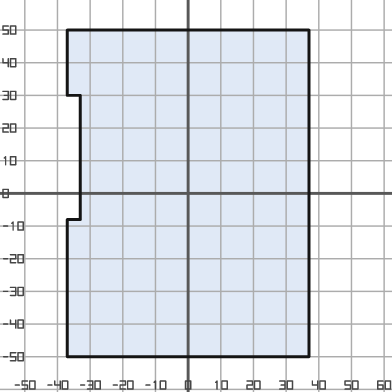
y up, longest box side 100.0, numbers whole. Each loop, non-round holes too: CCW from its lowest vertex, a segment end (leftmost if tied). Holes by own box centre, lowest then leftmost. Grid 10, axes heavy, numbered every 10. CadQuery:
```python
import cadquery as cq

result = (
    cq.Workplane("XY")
    .moveTo(-37.0, -50.0)
    .lineTo(37.0, -50.0)
    .lineTo(37.0, 50.0)
    .lineTo(-37.0, 50.0)
    .lineTo(-37.0, 30.0)
    .lineTo(-33.0, 30.0)
    .lineTo(-33.0, -8.0)
    .lineTo(-37.0, -8.0)
    .close()
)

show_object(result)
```